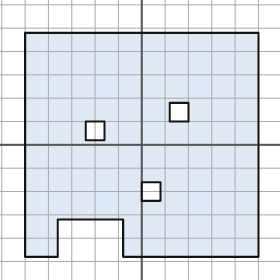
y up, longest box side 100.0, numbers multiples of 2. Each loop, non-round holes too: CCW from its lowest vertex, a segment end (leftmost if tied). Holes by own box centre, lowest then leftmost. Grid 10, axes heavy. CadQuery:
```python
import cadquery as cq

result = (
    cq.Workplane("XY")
    .moveTo(-50.0, -48.0)
    .lineTo(-36.0, -48.0)
    .lineTo(-36.0, -32.0)
    .lineTo(-8.0, -32.0)
    .lineTo(-8.0, -48.0)
    .lineTo(50.0, -48.0)
    .lineTo(50.0, 48.0)
    .lineTo(-50.0, 48.0)
    .close()
    .moveTo(0.0, -24.0)
    .lineTo(8.0, -24.0)
    .lineTo(8.0, -16.0)
    .lineTo(0.0, -16.0)
    .close()
    .moveTo(-24.0, 2.0)
    .lineTo(-16.0, 2.0)
    .lineTo(-16.0, 10.0)
    .lineTo(-24.0, 10.0)
    .close()
    .moveTo(12.0, 10.0)
    .lineTo(20.0, 10.0)
    .lineTo(20.0, 18.0)
    .lineTo(12.0, 18.0)
    .close()
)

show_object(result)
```